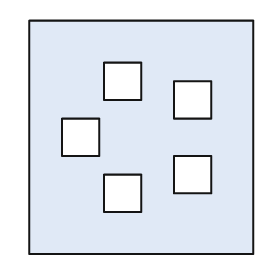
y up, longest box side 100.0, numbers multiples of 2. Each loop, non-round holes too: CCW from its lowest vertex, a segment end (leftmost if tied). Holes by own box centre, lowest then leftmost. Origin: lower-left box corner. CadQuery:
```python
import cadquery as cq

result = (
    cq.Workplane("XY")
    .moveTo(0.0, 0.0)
    .lineTo(96.0, 0.0)
    .lineTo(96.0, 100.0)
    .lineTo(0.0, 100.0)
    .close()
    .moveTo(32.0, 18.0)
    .lineTo(48.0, 18.0)
    .lineTo(48.0, 34.0)
    .lineTo(32.0, 34.0)
    .close()
    .moveTo(62.0, 26.0)
    .lineTo(78.0, 26.0)
    .lineTo(78.0, 42.0)
    .lineTo(62.0, 42.0)
    .close()
    .moveTo(14.0, 42.0)
    .lineTo(30.0, 42.0)
    .lineTo(30.0, 58.0)
    .lineTo(14.0, 58.0)
    .close()
    .moveTo(62.0, 58.0)
    .lineTo(78.0, 58.0)
    .lineTo(78.0, 74.0)
    .lineTo(62.0, 74.0)
    .close()
    .moveTo(32.0, 66.0)
    .lineTo(48.0, 66.0)
    .lineTo(48.0, 82.0)
    .lineTo(32.0, 82.0)
    .close()
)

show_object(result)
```